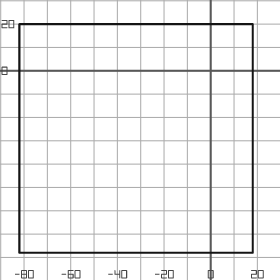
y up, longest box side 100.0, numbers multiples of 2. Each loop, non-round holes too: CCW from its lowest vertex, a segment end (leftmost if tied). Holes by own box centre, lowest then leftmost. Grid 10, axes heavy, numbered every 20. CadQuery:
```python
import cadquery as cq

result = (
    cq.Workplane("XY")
    .moveTo(-82.0, -78.0)
    .lineTo(18.0, -78.0)
    .lineTo(18.0, 20.0)
    .lineTo(-82.0, 20.0)
    .close()
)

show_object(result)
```